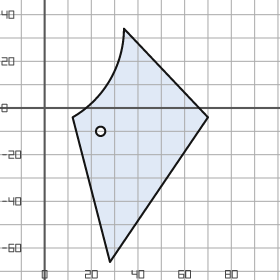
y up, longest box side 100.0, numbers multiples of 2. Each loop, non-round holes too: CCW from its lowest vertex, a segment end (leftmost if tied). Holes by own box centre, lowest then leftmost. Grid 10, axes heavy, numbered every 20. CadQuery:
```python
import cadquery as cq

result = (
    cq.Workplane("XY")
    .moveTo(28.0, -66.0)
    .lineTo(70.0, -4.0)
    .lineTo(34.0, 34.0)
    .threePointArc((28.0, 12.0), (12.0, -4.0))
    .close()
    .moveTo(24.0, -10.0)
    .circle(2.0)
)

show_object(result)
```